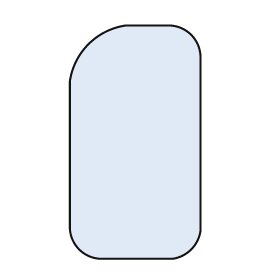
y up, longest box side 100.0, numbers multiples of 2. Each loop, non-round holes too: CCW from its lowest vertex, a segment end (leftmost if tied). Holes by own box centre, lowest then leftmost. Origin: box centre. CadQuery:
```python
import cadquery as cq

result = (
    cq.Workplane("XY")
    .moveTo(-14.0, -50.0)
    .lineTo(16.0, -50.0)
    .threePointArc((24.0, -46.0), (28.0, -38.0))
    .lineTo(28.0, 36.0)
    .threePointArc((24.0, 46.0), (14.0, 50.0))
    .lineTo(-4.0, 50.0)
    .threePointArc((-20.0, 42.0), (-28.0, 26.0))
    .lineTo(-28.0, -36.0)
    .threePointArc((-24.0, -46.0), (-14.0, -50.0))
    .close()
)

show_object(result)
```